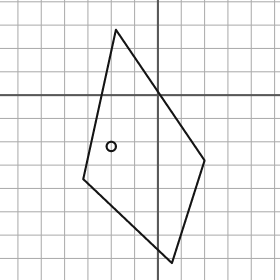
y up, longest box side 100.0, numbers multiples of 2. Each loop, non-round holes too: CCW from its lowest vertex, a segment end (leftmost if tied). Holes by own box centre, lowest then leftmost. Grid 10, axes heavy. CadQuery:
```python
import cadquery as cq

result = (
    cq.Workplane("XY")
    .moveTo(6.0, -72.0)
    .lineTo(20.0, -28.0)
    .lineTo(-18.0, 28.0)
    .lineTo(-32.0, -36.0)
    .close()
    .moveTo(-20.0, -22.0)
    .circle(2.0)
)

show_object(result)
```